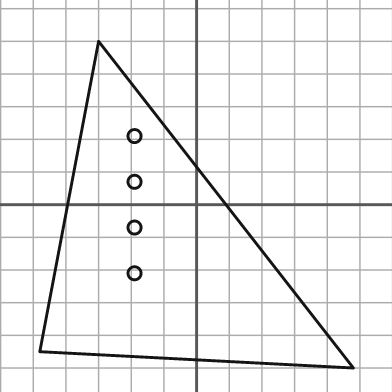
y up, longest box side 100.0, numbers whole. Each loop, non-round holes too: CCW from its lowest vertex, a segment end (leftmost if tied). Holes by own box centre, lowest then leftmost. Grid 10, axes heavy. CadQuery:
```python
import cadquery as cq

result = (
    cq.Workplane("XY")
    .moveTo(48.0, -50.0)
    .lineTo(-30.0, 50.0)
    .lineTo(-48.0, -45.0)
    .close()
    .moveTo(-19.0, -21.0)
    .circle(2.0)
    .moveTo(-19.0, -7.0)
    .circle(2.0)
    .moveTo(-19.0, 7.0)
    .circle(2.0)
    .moveTo(-19.0, 21.0)
    .circle(2.0)
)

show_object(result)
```